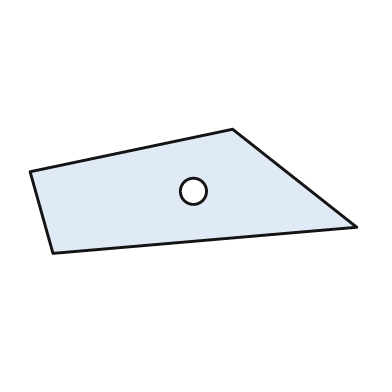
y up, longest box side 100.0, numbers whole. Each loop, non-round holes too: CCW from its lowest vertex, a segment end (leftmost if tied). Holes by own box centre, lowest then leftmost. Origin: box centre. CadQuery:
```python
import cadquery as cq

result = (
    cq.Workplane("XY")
    .moveTo(-43.0, -19.0)
    .lineTo(50.0, -11.0)
    .lineTo(12.0, 19.0)
    .lineTo(-50.0, 6.0)
    .close()
    .moveTo(0.0, 0.0)
    .circle(4.0)
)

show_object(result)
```